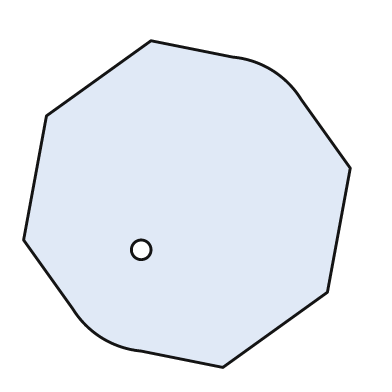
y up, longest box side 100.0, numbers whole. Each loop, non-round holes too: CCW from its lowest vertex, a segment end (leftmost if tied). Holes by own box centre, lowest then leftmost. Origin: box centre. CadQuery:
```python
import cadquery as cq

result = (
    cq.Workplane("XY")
    .moveTo(11.0, -50.0)
    .lineTo(43.0, -27.0)
    .lineTo(50.0, 11.0)
    .lineTo(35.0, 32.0)
    .threePointArc((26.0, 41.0), (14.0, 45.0))
    .lineTo(-11.0, 50.0)
    .lineTo(-43.0, 27.0)
    .lineTo(-50.0, -11.0)
    .lineTo(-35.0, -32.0)
    .threePointArc((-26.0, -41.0), (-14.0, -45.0))
    .close()
    .moveTo(-14.0, -14.0)
    .circle(3.0)
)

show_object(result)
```